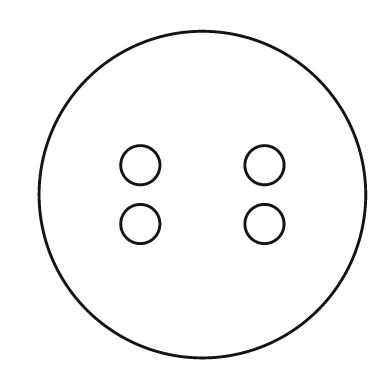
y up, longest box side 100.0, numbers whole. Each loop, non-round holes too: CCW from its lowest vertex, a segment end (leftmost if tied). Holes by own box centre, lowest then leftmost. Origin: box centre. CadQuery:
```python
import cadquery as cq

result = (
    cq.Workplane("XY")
    .moveTo(0.0, 0.0)
    .circle(50.0)
    .moveTo(-19.0, -9.0)
    .circle(6.0)
    .moveTo(19.0, -9.0)
    .circle(6.0)
    .moveTo(-19.0, 9.0)
    .circle(6.0)
    .moveTo(19.0, 9.0)
    .circle(6.0)
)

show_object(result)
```